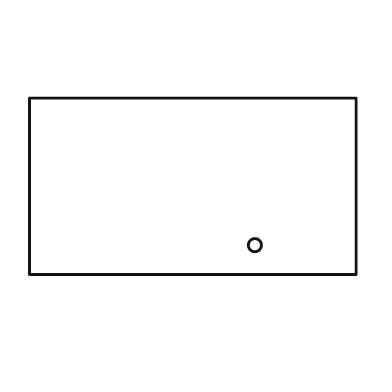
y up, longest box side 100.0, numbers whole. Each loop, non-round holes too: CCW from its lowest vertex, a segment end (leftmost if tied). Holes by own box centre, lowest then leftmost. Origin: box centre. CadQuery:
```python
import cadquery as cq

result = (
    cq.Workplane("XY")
    .moveTo(-50.0, -27.0)
    .lineTo(50.0, -27.0)
    .lineTo(50.0, 27.0)
    .lineTo(-50.0, 27.0)
    .close()
    .moveTo(19.0, -18.0)
    .circle(2.0)
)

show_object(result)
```